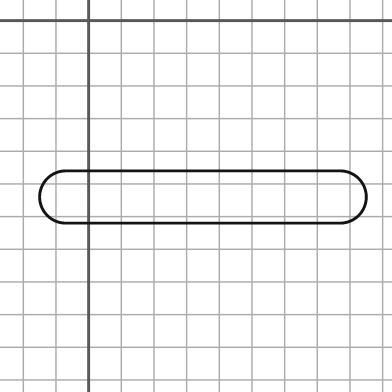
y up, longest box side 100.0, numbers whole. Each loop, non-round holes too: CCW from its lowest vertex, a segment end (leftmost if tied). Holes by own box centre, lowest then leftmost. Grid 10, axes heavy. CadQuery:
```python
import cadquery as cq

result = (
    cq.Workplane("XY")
    .moveTo(-7.0, -62.0)
    .lineTo(77.0, -62.0)
    .threePointArc((85.0, -54.0), (77.0, -46.0))
    .lineTo(-7.0, -46.0)
    .threePointArc((-15.0, -54.0), (-7.0, -62.0))
    .close()
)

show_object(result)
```